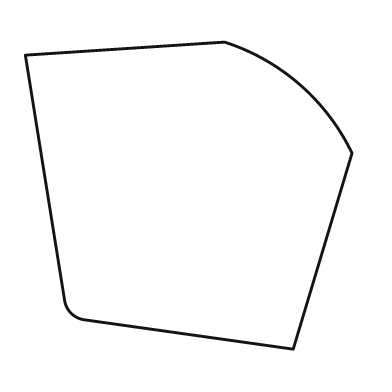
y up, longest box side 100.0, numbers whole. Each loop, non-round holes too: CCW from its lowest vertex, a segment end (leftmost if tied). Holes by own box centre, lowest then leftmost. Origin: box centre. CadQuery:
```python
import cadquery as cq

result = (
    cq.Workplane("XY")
    .moveTo(32.0, -47.0)
    .lineTo(50.0, 13.0)
    .threePointArc((34.0, 34.0), (11.0, 47.0))
    .lineTo(-50.0, 43.0)
    .lineTo(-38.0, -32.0)
    .threePointArc((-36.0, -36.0), (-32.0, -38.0))
    .close()
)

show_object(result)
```